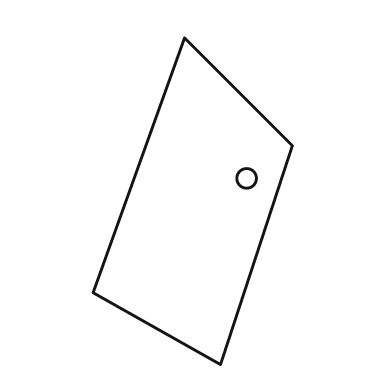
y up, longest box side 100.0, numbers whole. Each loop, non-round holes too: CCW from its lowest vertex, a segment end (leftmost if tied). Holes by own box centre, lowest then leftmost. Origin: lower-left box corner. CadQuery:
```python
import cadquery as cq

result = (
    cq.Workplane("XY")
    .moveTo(39.0, 0.0)
    .lineTo(61.0, 67.0)
    .lineTo(28.0, 100.0)
    .lineTo(0.0, 22.0)
    .close()
    .moveTo(47.0, 57.0)
    .circle(3.0)
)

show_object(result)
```